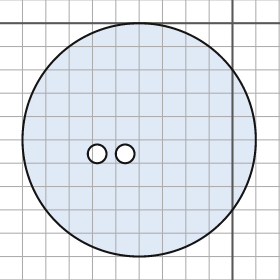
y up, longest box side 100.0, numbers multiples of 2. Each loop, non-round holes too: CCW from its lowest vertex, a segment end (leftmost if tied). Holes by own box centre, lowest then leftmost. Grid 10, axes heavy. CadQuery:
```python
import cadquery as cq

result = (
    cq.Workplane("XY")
    .moveTo(-40.0, -50.0)
    .circle(50.0)
    .moveTo(-58.0, -56.0)
    .circle(4.0)
    .moveTo(-46.0, -56.0)
    .circle(4.0)
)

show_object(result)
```